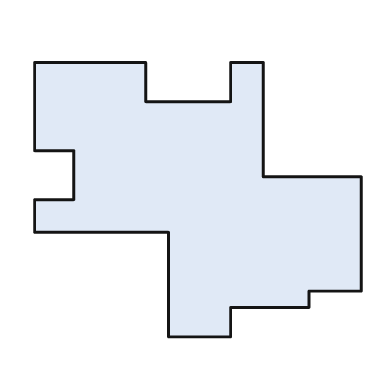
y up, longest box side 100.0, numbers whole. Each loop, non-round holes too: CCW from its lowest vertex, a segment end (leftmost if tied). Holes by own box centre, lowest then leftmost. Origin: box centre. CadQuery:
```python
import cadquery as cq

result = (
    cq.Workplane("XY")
    .moveTo(-9.0, -42.0)
    .lineTo(10.0, -42.0)
    .lineTo(10.0, -33.0)
    .lineTo(34.0, -33.0)
    .lineTo(34.0, -28.0)
    .lineTo(50.0, -28.0)
    .lineTo(50.0, 7.0)
    .lineTo(20.0, 7.0)
    .lineTo(20.0, 42.0)
    .lineTo(10.0, 42.0)
    .lineTo(10.0, 30.0)
    .lineTo(-16.0, 30.0)
    .lineTo(-16.0, 42.0)
    .lineTo(-50.0, 42.0)
    .lineTo(-50.0, 15.0)
    .lineTo(-38.0, 15.0)
    .lineTo(-38.0, 0.0)
    .lineTo(-50.0, 0.0)
    .lineTo(-50.0, -10.0)
    .lineTo(-9.0, -10.0)
    .close()
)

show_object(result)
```